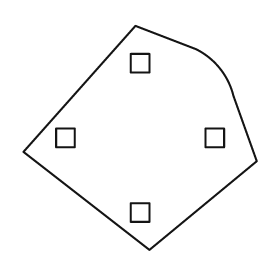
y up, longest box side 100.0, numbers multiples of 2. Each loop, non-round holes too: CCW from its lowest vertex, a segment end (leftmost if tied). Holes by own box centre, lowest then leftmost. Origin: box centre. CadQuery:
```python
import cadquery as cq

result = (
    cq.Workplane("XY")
    .moveTo(4.0, -48.0)
    .lineTo(50.0, -10.0)
    .lineTo(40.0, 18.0)
    .threePointArc((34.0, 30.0), (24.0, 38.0))
    .lineTo(-2.0, 48.0)
    .lineTo(-50.0, -6.0)
    .close()
    .moveTo(-4.0, -36.0)
    .lineTo(4.0, -36.0)
    .lineTo(4.0, -28.0)
    .lineTo(-4.0, -28.0)
    .close()
    .moveTo(-36.0, -4.0)
    .lineTo(-28.0, -4.0)
    .lineTo(-28.0, 4.0)
    .lineTo(-36.0, 4.0)
    .close()
    .moveTo(28.0, -4.0)
    .lineTo(36.0, -4.0)
    .lineTo(36.0, 4.0)
    .lineTo(28.0, 4.0)
    .close()
    .moveTo(-4.0, 28.0)
    .lineTo(4.0, 28.0)
    .lineTo(4.0, 36.0)
    .lineTo(-4.0, 36.0)
    .close()
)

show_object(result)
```